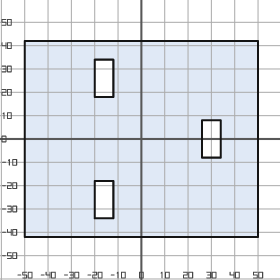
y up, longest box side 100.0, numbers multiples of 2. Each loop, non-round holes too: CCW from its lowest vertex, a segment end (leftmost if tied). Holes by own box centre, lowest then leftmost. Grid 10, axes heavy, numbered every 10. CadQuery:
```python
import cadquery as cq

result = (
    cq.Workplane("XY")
    .moveTo(-50.0, -42.0)
    .lineTo(50.0, -42.0)
    .lineTo(50.0, 42.0)
    .lineTo(-50.0, 42.0)
    .close()
    .moveTo(-20.0, -34.0)
    .lineTo(-12.0, -34.0)
    .lineTo(-12.0, -18.0)
    .lineTo(-20.0, -18.0)
    .close()
    .moveTo(26.0, -8.0)
    .lineTo(34.0, -8.0)
    .lineTo(34.0, 8.0)
    .lineTo(26.0, 8.0)
    .close()
    .moveTo(-20.0, 18.0)
    .lineTo(-12.0, 18.0)
    .lineTo(-12.0, 34.0)
    .lineTo(-20.0, 34.0)
    .close()
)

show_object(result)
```